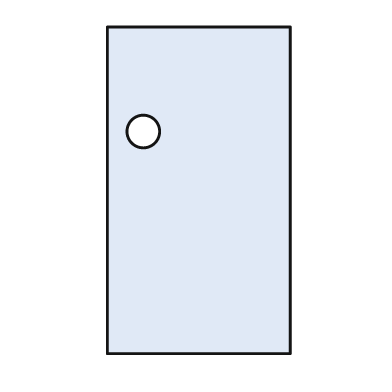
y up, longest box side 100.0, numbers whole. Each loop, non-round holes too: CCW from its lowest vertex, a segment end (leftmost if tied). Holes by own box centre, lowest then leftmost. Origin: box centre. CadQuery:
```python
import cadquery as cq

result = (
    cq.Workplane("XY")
    .moveTo(-28.0, -50.0)
    .lineTo(28.0, -50.0)
    .lineTo(28.0, 50.0)
    .lineTo(-28.0, 50.0)
    .close()
    .moveTo(-17.0, 18.0)
    .circle(5.0)
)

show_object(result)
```